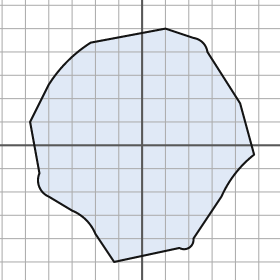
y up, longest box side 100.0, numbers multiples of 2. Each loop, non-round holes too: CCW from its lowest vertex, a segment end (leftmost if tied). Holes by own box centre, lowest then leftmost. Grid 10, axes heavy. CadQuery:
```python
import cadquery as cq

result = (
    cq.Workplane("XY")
    .moveTo(-12.0, -50.0)
    .lineTo(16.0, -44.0)
    .threePointArc((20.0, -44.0), (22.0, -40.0))
    .lineTo(34.0, -22.0)
    .threePointArc((40.0, -12.0), (48.0, -4.0))
    .lineTo(42.0, 18.0)
    .lineTo(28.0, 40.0)
    .threePointArc((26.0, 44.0), (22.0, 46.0))
    .lineTo(10.0, 50.0)
    .lineTo(-22.0, 44.0)
    .threePointArc((-32.0, 36.0), (-40.0, 26.0))
    .lineTo(-48.0, 10.0)
    .lineTo(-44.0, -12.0)
    .threePointArc((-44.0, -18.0), (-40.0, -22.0))
    .lineTo(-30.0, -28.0)
    .threePointArc((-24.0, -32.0), (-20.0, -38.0))
    .close()
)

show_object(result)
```